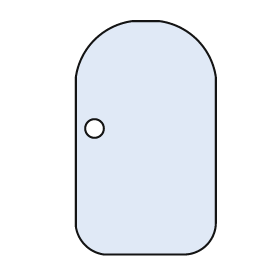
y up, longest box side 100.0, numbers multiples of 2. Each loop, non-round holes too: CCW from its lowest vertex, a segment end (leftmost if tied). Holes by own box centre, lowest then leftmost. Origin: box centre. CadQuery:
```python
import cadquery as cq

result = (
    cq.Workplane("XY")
    .moveTo(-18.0, -50.0)
    .lineTo(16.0, -50.0)
    .threePointArc((26.0, -46.0), (30.0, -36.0))
    .lineTo(30.0, 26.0)
    .threePointArc((22.0, 42.0), (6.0, 50.0))
    .lineTo(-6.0, 50.0)
    .threePointArc((-22.0, 42.0), (-30.0, 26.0))
    .lineTo(-30.0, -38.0)
    .threePointArc((-26.0, -46.0), (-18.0, -50.0))
    .close()
    .moveTo(-22.0, 4.0)
    .circle(4.0)
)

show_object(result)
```